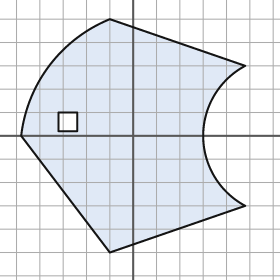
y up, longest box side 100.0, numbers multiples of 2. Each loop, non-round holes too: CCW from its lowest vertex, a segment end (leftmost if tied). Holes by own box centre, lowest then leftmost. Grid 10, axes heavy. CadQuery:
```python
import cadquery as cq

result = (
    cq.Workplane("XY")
    .moveTo(-10.0, -50.0)
    .lineTo(48.0, -30.0)
    .threePointArc((30.0, 0.0), (48.0, 30.0))
    .lineTo(-10.0, 50.0)
    .threePointArc((-36.0, 30.0), (-48.0, 0.0))
    .close()
    .moveTo(-32.0, 2.0)
    .lineTo(-24.0, 2.0)
    .lineTo(-24.0, 10.0)
    .lineTo(-32.0, 10.0)
    .close()
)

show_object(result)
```